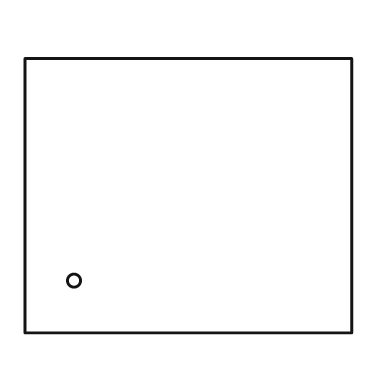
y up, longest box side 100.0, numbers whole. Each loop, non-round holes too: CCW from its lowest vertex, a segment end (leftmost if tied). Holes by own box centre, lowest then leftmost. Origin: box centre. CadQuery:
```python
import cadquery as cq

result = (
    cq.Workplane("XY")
    .moveTo(-50.0, -42.0)
    .lineTo(50.0, -42.0)
    .lineTo(50.0, 42.0)
    .lineTo(-50.0, 42.0)
    .close()
    .moveTo(-35.0, -26.0)
    .circle(2.0)
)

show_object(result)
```